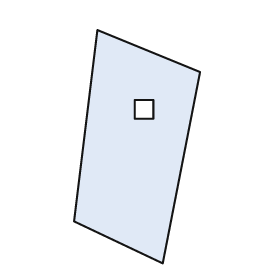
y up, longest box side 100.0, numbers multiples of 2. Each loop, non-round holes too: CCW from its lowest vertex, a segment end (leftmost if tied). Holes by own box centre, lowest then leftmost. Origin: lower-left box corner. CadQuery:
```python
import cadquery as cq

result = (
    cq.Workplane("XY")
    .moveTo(38.0, 0.0)
    .lineTo(54.0, 82.0)
    .lineTo(10.0, 100.0)
    .lineTo(0.0, 18.0)
    .close()
    .moveTo(26.0, 62.0)
    .lineTo(34.0, 62.0)
    .lineTo(34.0, 70.0)
    .lineTo(26.0, 70.0)
    .close()
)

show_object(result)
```